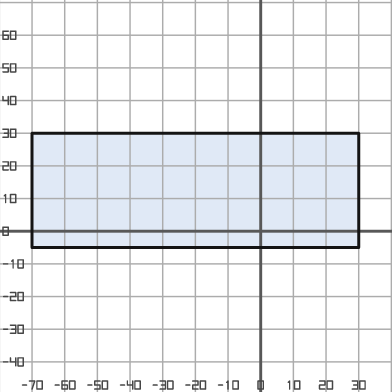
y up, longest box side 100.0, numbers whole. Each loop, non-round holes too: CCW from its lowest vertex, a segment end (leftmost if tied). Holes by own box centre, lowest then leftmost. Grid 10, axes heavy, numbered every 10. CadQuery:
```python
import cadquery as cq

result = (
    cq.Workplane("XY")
    .moveTo(-70.0, -5.0)
    .lineTo(30.0, -5.0)
    .lineTo(30.0, 30.0)
    .lineTo(-70.0, 30.0)
    .close()
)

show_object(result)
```